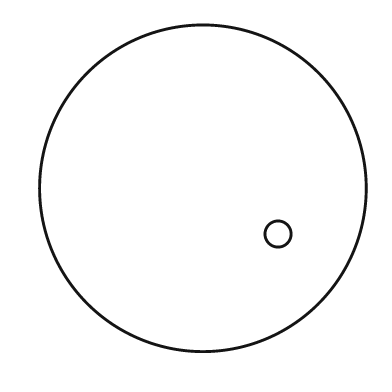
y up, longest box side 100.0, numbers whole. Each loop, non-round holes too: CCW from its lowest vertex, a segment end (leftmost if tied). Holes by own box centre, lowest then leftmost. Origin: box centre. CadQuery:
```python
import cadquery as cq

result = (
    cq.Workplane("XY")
    .moveTo(0.0, 0.0)
    .circle(50.0)
    .moveTo(23.0, -14.0)
    .circle(4.0)
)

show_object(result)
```